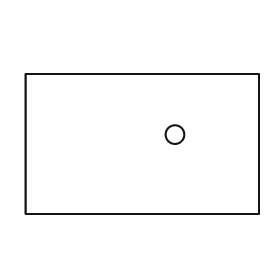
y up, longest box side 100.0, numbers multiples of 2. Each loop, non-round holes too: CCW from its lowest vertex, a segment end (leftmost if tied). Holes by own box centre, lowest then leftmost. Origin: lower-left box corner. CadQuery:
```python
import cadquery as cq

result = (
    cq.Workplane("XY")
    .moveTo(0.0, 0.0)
    .lineTo(100.0, 0.0)
    .lineTo(100.0, 60.0)
    .lineTo(0.0, 60.0)
    .close()
    .moveTo(64.0, 34.0)
    .circle(4.0)
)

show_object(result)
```